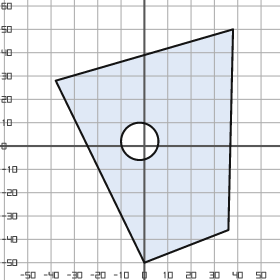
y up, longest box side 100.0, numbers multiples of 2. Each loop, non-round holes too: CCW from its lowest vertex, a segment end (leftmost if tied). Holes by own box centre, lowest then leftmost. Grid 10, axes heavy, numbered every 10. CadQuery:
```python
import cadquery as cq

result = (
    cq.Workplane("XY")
    .moveTo(0.0, -50.0)
    .lineTo(36.0, -36.0)
    .lineTo(38.0, 50.0)
    .lineTo(-38.0, 28.0)
    .close()
    .moveTo(-2.0, 2.0)
    .circle(8.0)
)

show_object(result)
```